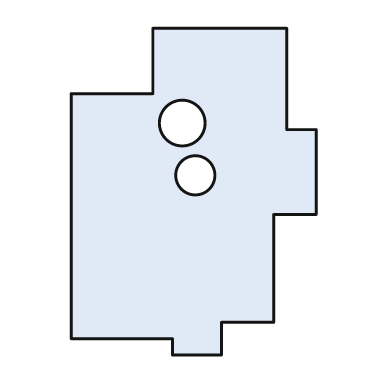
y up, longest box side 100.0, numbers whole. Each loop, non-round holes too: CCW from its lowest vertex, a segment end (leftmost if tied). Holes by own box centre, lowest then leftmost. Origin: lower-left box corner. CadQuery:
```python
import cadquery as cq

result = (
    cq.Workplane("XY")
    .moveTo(31.0, 0.0)
    .lineTo(46.0, 0.0)
    .lineTo(46.0, 10.0)
    .lineTo(62.0, 10.0)
    .lineTo(62.0, 43.0)
    .lineTo(75.0, 43.0)
    .lineTo(75.0, 69.0)
    .lineTo(66.0, 69.0)
    .lineTo(66.0, 100.0)
    .lineTo(25.0, 100.0)
    .lineTo(25.0, 80.0)
    .lineTo(0.0, 80.0)
    .lineTo(0.0, 5.0)
    .lineTo(31.0, 5.0)
    .close()
    .moveTo(38.0, 55.0)
    .circle(6.0)
    .moveTo(34.0, 71.0)
    .circle(7.0)
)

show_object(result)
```